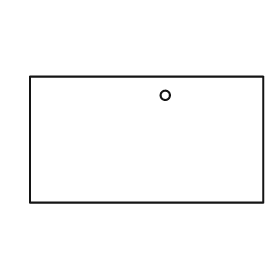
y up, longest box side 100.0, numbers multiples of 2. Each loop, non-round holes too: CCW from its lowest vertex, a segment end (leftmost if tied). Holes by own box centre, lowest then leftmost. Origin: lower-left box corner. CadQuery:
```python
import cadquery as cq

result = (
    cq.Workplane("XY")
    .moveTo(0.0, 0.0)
    .lineTo(100.0, 0.0)
    .lineTo(100.0, 54.0)
    .lineTo(0.0, 54.0)
    .close()
    .moveTo(58.0, 46.0)
    .circle(2.0)
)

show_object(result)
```